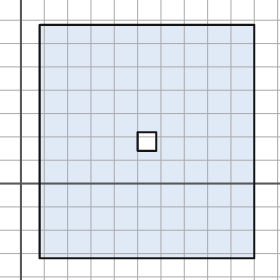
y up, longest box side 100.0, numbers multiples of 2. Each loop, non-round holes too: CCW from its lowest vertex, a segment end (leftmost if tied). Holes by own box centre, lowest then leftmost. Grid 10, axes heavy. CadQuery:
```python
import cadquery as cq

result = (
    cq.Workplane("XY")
    .moveTo(8.0, -32.0)
    .lineTo(100.0, -32.0)
    .lineTo(100.0, 68.0)
    .lineTo(8.0, 68.0)
    .close()
    .moveTo(50.0, 14.0)
    .lineTo(58.0, 14.0)
    .lineTo(58.0, 22.0)
    .lineTo(50.0, 22.0)
    .close()
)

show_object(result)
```